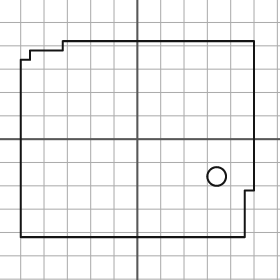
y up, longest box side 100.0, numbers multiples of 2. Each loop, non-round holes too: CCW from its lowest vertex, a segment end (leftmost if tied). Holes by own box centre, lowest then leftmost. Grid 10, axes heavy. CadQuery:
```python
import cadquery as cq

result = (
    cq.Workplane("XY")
    .moveTo(-50.0, -42.0)
    .lineTo(46.0, -42.0)
    .lineTo(46.0, -22.0)
    .lineTo(50.0, -22.0)
    .lineTo(50.0, 42.0)
    .lineTo(-32.0, 42.0)
    .lineTo(-32.0, 38.0)
    .lineTo(-46.0, 38.0)
    .lineTo(-46.0, 34.0)
    .lineTo(-50.0, 34.0)
    .close()
    .moveTo(34.0, -16.0)
    .circle(4.0)
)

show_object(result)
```